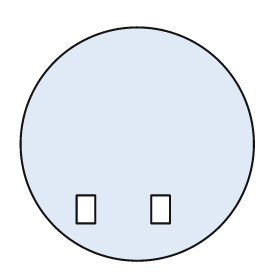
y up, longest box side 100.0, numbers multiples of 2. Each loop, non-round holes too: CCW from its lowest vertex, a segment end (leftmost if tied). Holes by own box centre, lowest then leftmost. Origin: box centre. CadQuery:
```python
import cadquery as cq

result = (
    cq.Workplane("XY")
    .moveTo(0.0, 0.0)
    .circle(50.0)
    .moveTo(-26.0, -34.0)
    .lineTo(-18.0, -34.0)
    .lineTo(-18.0, -22.0)
    .lineTo(-26.0, -22.0)
    .close()
    .moveTo(6.0, -34.0)
    .lineTo(14.0, -34.0)
    .lineTo(14.0, -22.0)
    .lineTo(6.0, -22.0)
    .close()
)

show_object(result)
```